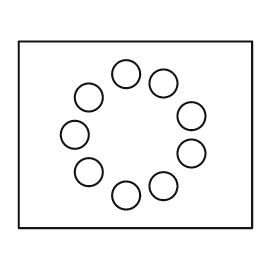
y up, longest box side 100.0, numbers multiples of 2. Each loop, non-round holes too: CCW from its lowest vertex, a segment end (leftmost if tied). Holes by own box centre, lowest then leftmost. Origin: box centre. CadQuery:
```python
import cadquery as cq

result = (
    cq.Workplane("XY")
    .moveTo(-50.0, -40.0)
    .lineTo(50.0, -40.0)
    .lineTo(50.0, 40.0)
    .lineTo(-50.0, 40.0)
    .close()
    .moveTo(-4.0, -26.0)
    .circle(6.0)
    .moveTo(12.0, -22.0)
    .circle(6.0)
    .moveTo(-20.0, -16.0)
    .circle(6.0)
    .moveTo(24.0, -8.0)
    .circle(6.0)
    .moveTo(-26.0, 0.0)
    .circle(6.0)
    .moveTo(24.0, 8.0)
    .circle(6.0)
    .moveTo(-20.0, 16.0)
    .circle(6.0)
    .moveTo(12.0, 22.0)
    .circle(6.0)
    .moveTo(-4.0, 26.0)
    .circle(6.0)
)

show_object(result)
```